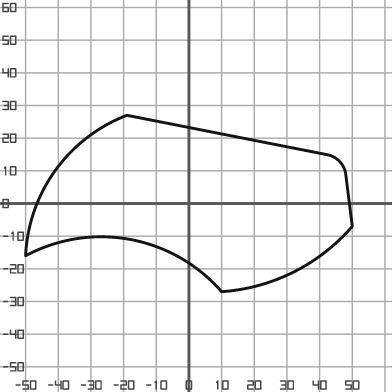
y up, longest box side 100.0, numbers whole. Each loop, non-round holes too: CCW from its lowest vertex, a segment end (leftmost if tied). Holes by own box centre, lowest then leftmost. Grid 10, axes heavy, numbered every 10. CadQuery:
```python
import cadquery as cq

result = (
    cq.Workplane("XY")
    .moveTo(10.0, -27.0)
    .threePointArc((32.0, -21.0), (50.0, -7.0))
    .lineTo(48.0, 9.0)
    .threePointArc((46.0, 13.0), (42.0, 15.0))
    .lineTo(-19.0, 27.0)
    .threePointArc((-41.0, 10.0), (-50.0, -16.0))
    .threePointArc((-18.0, -11.0), (10.0, -27.0))
    .close()
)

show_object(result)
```